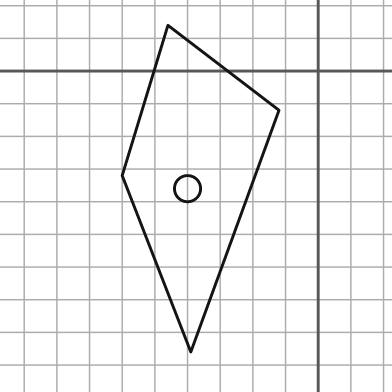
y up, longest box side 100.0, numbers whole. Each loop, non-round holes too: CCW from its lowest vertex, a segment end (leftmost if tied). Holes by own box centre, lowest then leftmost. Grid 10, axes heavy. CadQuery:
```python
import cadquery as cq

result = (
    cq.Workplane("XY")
    .moveTo(-39.0, -86.0)
    .lineTo(-12.0, -12.0)
    .lineTo(-46.0, 14.0)
    .lineTo(-60.0, -32.0)
    .close()
    .moveTo(-40.0, -36.0)
    .circle(4.0)
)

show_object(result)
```